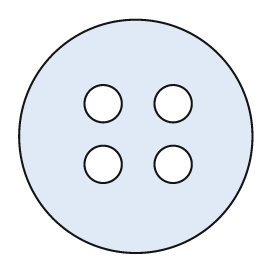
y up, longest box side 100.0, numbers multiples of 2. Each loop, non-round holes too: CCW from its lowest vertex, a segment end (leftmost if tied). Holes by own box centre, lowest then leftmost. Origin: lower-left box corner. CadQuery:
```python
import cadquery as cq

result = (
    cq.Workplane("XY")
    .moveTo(50.0, 50.0)
    .circle(50.0)
    .moveTo(36.0, 38.0)
    .circle(8.0)
    .moveTo(66.0, 38.0)
    .circle(8.0)
    .moveTo(36.0, 64.0)
    .circle(8.0)
    .moveTo(66.0, 64.0)
    .circle(8.0)
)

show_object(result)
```